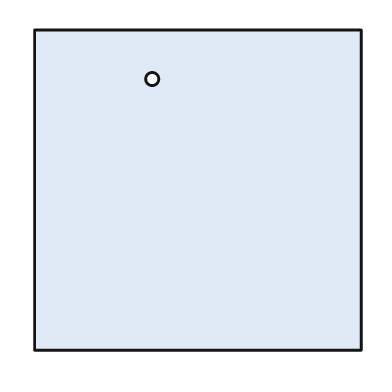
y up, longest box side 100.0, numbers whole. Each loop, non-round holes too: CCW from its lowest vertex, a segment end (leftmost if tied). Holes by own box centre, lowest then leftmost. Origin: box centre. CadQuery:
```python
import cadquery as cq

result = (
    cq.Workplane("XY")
    .moveTo(-50.0, -49.0)
    .lineTo(50.0, -49.0)
    .lineTo(50.0, 49.0)
    .lineTo(-50.0, 49.0)
    .close()
    .moveTo(-14.0, 34.0)
    .circle(2.0)
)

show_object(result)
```